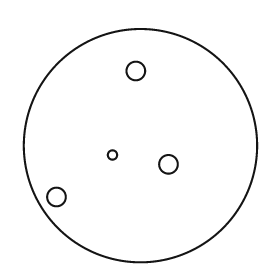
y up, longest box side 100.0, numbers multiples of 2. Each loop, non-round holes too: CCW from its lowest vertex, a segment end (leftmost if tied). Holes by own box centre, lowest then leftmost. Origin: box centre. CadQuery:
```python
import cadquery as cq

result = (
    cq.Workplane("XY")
    .moveTo(0.0, 0.0)
    .circle(50.0)
    .moveTo(-36.0, -22.0)
    .circle(4.0)
    .moveTo(12.0, -8.0)
    .circle(4.0)
    .moveTo(-12.0, -4.0)
    .circle(2.0)
    .moveTo(-2.0, 32.0)
    .circle(4.0)
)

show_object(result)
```